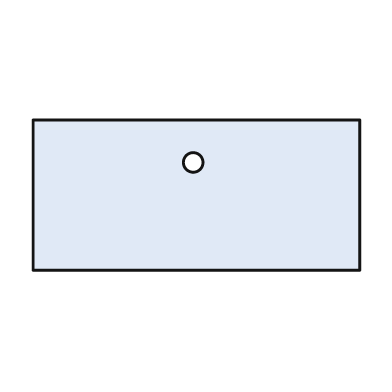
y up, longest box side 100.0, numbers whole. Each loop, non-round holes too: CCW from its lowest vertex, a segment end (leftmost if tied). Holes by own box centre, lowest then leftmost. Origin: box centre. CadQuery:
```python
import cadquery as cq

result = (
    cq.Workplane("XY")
    .moveTo(-50.0, -23.0)
    .lineTo(50.0, -23.0)
    .lineTo(50.0, 23.0)
    .lineTo(-50.0, 23.0)
    .close()
    .moveTo(-1.0, 10.0)
    .circle(3.0)
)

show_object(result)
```